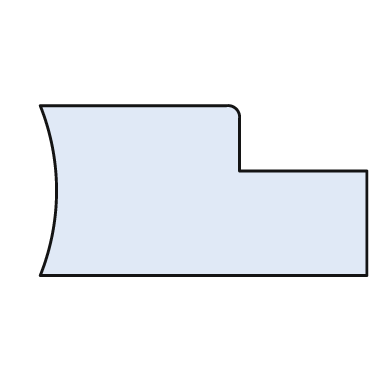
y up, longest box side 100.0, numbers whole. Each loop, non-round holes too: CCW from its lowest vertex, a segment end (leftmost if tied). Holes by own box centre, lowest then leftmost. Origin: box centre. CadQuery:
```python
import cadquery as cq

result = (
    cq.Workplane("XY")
    .moveTo(-50.0, -26.0)
    .lineTo(50.0, -26.0)
    .lineTo(50.0, 6.0)
    .lineTo(11.0, 6.0)
    .lineTo(11.0, 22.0)
    .threePointArc((10.0, 25.0), (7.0, 26.0))
    .lineTo(-50.0, 26.0)
    .threePointArc((-45.0, 0.0), (-50.0, -26.0))
    .close()
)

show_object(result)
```